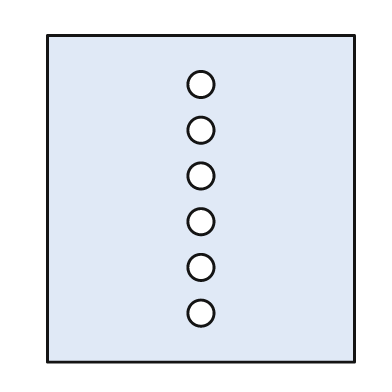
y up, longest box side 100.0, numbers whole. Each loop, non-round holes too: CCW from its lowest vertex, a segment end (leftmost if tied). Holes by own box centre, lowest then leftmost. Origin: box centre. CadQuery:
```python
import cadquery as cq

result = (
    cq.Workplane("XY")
    .moveTo(-47.0, -50.0)
    .lineTo(47.0, -50.0)
    .lineTo(47.0, 50.0)
    .lineTo(-47.0, 50.0)
    .close()
    .moveTo(0.0, -35.0)
    .circle(4.0)
    .moveTo(0.0, -21.0)
    .circle(4.0)
    .moveTo(0.0, -7.0)
    .circle(4.0)
    .moveTo(0.0, 7.0)
    .circle(4.0)
    .moveTo(0.0, 21.0)
    .circle(4.0)
    .moveTo(0.0, 35.0)
    .circle(4.0)
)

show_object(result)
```